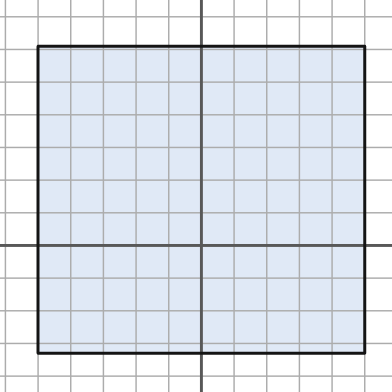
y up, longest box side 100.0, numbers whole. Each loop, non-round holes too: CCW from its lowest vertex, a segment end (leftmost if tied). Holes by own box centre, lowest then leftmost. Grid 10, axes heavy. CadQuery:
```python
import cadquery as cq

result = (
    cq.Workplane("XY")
    .moveTo(-50.0, -33.0)
    .lineTo(50.0, -33.0)
    .lineTo(50.0, 61.0)
    .lineTo(-50.0, 61.0)
    .close()
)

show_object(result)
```